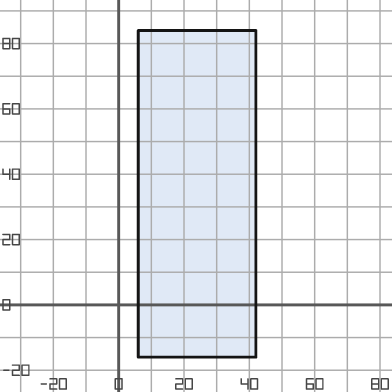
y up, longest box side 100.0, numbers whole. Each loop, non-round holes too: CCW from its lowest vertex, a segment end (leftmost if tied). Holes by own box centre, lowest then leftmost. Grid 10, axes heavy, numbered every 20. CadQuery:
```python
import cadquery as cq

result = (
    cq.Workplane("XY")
    .moveTo(6.0, -16.0)
    .lineTo(42.0, -16.0)
    .lineTo(42.0, 84.0)
    .lineTo(6.0, 84.0)
    .close()
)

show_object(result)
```